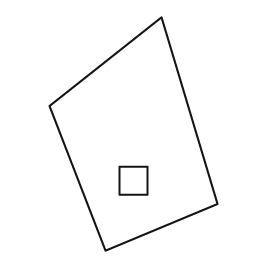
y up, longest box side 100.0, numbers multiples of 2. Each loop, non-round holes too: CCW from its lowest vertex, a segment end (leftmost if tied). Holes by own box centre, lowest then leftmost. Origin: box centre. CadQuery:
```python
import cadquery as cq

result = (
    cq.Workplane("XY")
    .moveTo(-12.0, -50.0)
    .lineTo(36.0, -30.0)
    .lineTo(12.0, 50.0)
    .lineTo(-36.0, 12.0)
    .close()
    .moveTo(-6.0, -26.0)
    .lineTo(6.0, -26.0)
    .lineTo(6.0, -14.0)
    .lineTo(-6.0, -14.0)
    .close()
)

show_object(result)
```